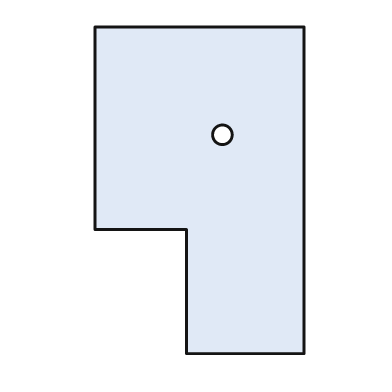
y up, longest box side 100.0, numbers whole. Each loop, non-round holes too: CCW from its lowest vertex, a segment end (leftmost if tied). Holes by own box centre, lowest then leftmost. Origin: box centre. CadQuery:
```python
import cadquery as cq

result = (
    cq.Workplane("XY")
    .moveTo(-4.0, -50.0)
    .lineTo(32.0, -50.0)
    .lineTo(32.0, 50.0)
    .lineTo(-32.0, 50.0)
    .lineTo(-32.0, -12.0)
    .lineTo(-4.0, -12.0)
    .close()
    .moveTo(7.0, 17.0)
    .circle(3.0)
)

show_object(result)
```